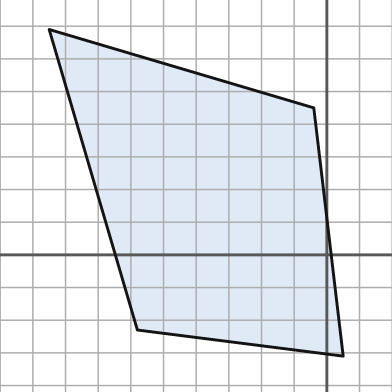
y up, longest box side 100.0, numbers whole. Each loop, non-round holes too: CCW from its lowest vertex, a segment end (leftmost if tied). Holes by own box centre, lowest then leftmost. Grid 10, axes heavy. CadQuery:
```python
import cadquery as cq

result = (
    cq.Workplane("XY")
    .moveTo(5.0, -31.0)
    .lineTo(-4.0, 45.0)
    .lineTo(-85.0, 69.0)
    .lineTo(-58.0, -23.0)
    .close()
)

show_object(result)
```